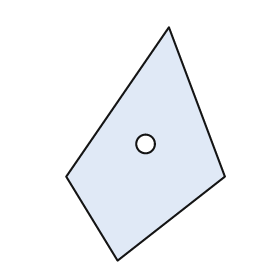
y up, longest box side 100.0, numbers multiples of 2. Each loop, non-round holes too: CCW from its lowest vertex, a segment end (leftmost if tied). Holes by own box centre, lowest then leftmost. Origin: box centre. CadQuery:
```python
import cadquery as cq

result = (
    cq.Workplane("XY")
    .moveTo(-12.0, -50.0)
    .lineTo(34.0, -14.0)
    .lineTo(10.0, 50.0)
    .lineTo(-34.0, -14.0)
    .close()
    .moveTo(0.0, 0.0)
    .circle(4.0)
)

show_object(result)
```